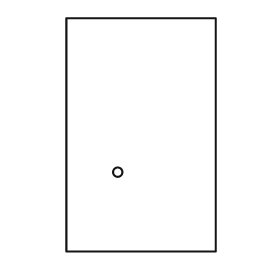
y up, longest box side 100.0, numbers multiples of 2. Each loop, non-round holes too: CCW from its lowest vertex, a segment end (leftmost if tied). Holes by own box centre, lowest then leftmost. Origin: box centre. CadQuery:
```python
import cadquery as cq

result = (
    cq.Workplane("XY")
    .moveTo(-32.0, -50.0)
    .lineTo(32.0, -50.0)
    .lineTo(32.0, 50.0)
    .lineTo(-32.0, 50.0)
    .close()
    .moveTo(-10.0, -16.0)
    .circle(2.0)
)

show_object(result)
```